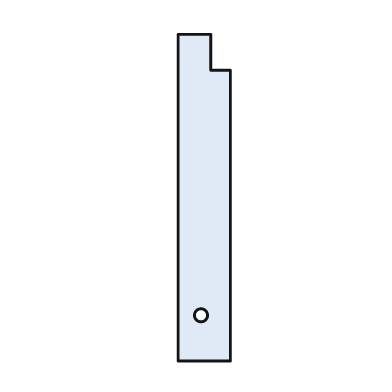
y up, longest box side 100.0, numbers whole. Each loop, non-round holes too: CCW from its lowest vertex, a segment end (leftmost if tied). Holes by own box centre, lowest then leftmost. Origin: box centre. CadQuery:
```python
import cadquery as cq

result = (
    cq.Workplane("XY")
    .moveTo(-8.0, -50.0)
    .lineTo(8.0, -50.0)
    .lineTo(8.0, 39.0)
    .lineTo(2.0, 39.0)
    .lineTo(2.0, 50.0)
    .lineTo(-8.0, 50.0)
    .close()
    .moveTo(-1.0, -36.0)
    .circle(2.0)
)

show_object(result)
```